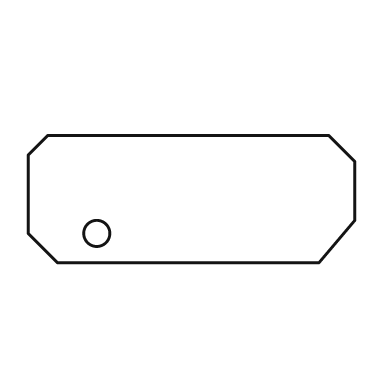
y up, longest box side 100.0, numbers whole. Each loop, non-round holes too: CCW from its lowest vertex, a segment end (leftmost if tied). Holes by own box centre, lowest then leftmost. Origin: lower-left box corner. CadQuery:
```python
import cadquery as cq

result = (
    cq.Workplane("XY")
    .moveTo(9.0, 0.0)
    .lineTo(89.0, 0.0)
    .lineTo(100.0, 13.0)
    .lineTo(100.0, 31.0)
    .lineTo(92.0, 39.0)
    .lineTo(6.0, 39.0)
    .lineTo(0.0, 33.0)
    .lineTo(0.0, 9.0)
    .close()
    .moveTo(21.0, 9.0)
    .circle(4.0)
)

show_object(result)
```